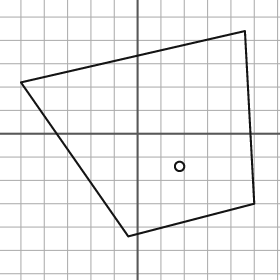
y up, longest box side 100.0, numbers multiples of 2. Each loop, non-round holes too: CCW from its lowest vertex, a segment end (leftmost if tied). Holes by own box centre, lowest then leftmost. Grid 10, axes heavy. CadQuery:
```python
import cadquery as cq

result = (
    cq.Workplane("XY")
    .moveTo(-4.0, -44.0)
    .lineTo(50.0, -30.0)
    .lineTo(46.0, 44.0)
    .lineTo(-50.0, 22.0)
    .close()
    .moveTo(18.0, -14.0)
    .circle(2.0)
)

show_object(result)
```